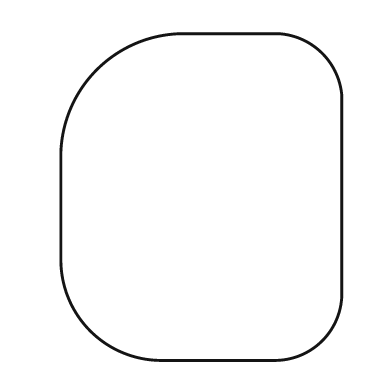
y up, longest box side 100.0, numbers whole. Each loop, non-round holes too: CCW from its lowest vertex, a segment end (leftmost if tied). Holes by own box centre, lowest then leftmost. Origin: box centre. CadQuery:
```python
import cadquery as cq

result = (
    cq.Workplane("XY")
    .moveTo(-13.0, -50.0)
    .lineTo(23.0, -50.0)
    .threePointArc((37.0, -44.0), (43.0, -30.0))
    .lineTo(43.0, 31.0)
    .threePointArc((37.0, 44.0), (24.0, 50.0))
    .lineTo(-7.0, 50.0)
    .threePointArc((-32.0, 39.0), (-43.0, 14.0))
    .lineTo(-43.0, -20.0)
    .threePointArc((-34.0, -41.0), (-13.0, -50.0))
    .close()
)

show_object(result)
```